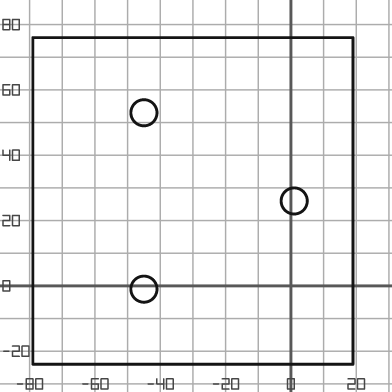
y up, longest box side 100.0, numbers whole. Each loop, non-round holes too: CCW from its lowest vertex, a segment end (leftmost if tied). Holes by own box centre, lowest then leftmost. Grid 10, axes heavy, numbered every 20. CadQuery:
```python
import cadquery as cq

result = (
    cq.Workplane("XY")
    .moveTo(-79.0, -24.0)
    .lineTo(19.0, -24.0)
    .lineTo(19.0, 76.0)
    .lineTo(-79.0, 76.0)
    .close()
    .moveTo(-45.0, -1.0)
    .circle(4.0)
    .moveTo(1.0, 26.0)
    .circle(4.0)
    .moveTo(-45.0, 53.0)
    .circle(4.0)
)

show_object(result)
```